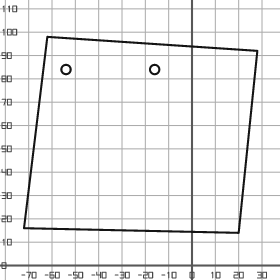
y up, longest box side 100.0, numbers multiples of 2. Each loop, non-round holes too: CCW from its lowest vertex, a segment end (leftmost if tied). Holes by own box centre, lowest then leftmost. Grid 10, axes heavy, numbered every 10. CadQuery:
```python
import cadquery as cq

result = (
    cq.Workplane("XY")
    .moveTo(20.0, 14.0)
    .lineTo(28.0, 92.0)
    .lineTo(-62.0, 98.0)
    .lineTo(-72.0, 16.0)
    .close()
    .moveTo(-54.0, 84.0)
    .circle(2.0)
    .moveTo(-16.0, 84.0)
    .circle(2.0)
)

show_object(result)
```